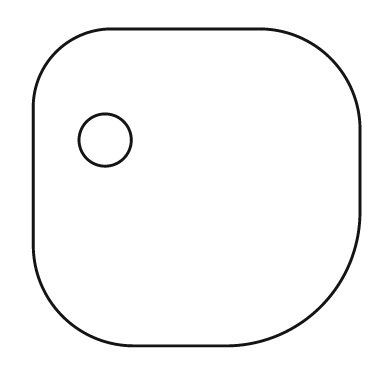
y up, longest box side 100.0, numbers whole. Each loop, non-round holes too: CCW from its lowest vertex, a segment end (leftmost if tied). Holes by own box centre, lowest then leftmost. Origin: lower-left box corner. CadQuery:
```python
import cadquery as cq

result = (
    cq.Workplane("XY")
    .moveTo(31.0, 0.0)
    .lineTo(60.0, 0.0)
    .threePointArc((88.0, 12.0), (100.0, 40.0))
    .lineTo(100.0, 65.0)
    .threePointArc((91.0, 88.0), (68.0, 97.0))
    .lineTo(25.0, 97.0)
    .threePointArc((7.0, 90.0), (0.0, 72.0))
    .lineTo(0.0, 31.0)
    .threePointArc((9.0, 9.0), (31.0, 0.0))
    .close()
    .moveTo(22.0, 63.0)
    .circle(8.0)
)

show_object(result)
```